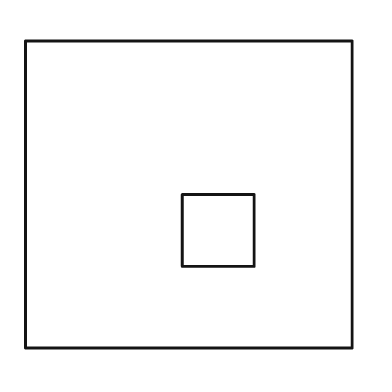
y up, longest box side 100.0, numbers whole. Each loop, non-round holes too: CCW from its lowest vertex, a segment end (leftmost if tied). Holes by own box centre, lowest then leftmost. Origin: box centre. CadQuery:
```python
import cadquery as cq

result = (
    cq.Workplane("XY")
    .moveTo(-50.0, -47.0)
    .lineTo(50.0, -47.0)
    .lineTo(50.0, 47.0)
    .lineTo(-50.0, 47.0)
    .close()
    .moveTo(-2.0, -22.0)
    .lineTo(20.0, -22.0)
    .lineTo(20.0, 0.0)
    .lineTo(-2.0, 0.0)
    .close()
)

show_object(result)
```